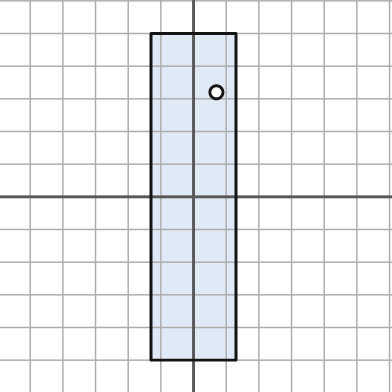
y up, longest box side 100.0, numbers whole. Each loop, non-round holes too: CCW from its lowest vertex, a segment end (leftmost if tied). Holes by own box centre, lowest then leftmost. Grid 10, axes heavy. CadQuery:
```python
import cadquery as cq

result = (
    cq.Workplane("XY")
    .moveTo(-13.0, -50.0)
    .lineTo(13.0, -50.0)
    .lineTo(13.0, 50.0)
    .lineTo(-13.0, 50.0)
    .close()
    .moveTo(7.0, 32.0)
    .circle(2.0)
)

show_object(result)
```